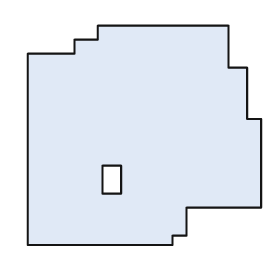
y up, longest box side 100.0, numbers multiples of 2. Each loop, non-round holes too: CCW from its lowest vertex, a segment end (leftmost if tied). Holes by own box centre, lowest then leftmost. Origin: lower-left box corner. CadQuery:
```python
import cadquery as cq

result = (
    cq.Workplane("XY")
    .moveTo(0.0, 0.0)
    .lineTo(62.0, 0.0)
    .lineTo(62.0, 4.0)
    .lineTo(68.0, 4.0)
    .lineTo(68.0, 16.0)
    .lineTo(100.0, 16.0)
    .lineTo(100.0, 54.0)
    .lineTo(94.0, 54.0)
    .lineTo(94.0, 76.0)
    .lineTo(86.0, 76.0)
    .lineTo(86.0, 94.0)
    .lineTo(30.0, 94.0)
    .lineTo(30.0, 88.0)
    .lineTo(20.0, 88.0)
    .lineTo(20.0, 82.0)
    .lineTo(0.0, 82.0)
    .close()
    .moveTo(32.0, 22.0)
    .lineTo(40.0, 22.0)
    .lineTo(40.0, 34.0)
    .lineTo(32.0, 34.0)
    .close()
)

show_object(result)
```